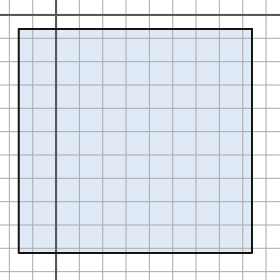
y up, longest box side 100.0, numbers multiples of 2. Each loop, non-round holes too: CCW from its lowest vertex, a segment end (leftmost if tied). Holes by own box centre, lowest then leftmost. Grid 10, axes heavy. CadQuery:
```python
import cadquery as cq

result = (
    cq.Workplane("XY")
    .moveTo(-16.0, -102.0)
    .lineTo(84.0, -102.0)
    .lineTo(84.0, -6.0)
    .lineTo(-16.0, -6.0)
    .close()
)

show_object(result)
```